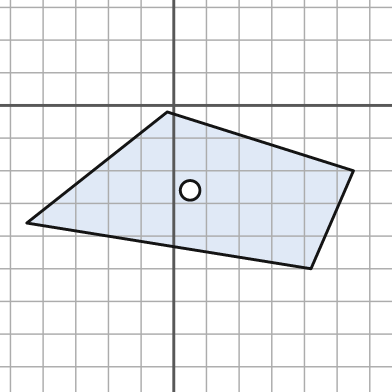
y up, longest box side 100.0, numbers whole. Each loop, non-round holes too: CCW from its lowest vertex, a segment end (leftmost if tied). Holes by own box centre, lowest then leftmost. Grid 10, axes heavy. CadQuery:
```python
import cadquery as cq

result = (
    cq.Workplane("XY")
    .moveTo(42.0, -50.0)
    .lineTo(55.0, -20.0)
    .lineTo(-2.0, -2.0)
    .lineTo(-45.0, -36.0)
    .close()
    .moveTo(5.0, -26.0)
    .circle(3.0)
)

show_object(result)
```